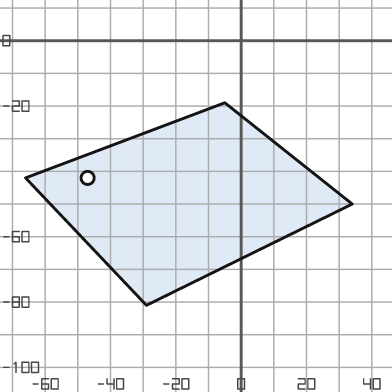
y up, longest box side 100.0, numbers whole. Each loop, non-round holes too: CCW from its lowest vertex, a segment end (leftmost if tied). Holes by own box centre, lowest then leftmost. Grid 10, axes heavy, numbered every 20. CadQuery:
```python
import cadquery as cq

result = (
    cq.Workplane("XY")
    .moveTo(-29.0, -81.0)
    .lineTo(34.0, -50.0)
    .lineTo(-5.0, -19.0)
    .lineTo(-66.0, -42.0)
    .close()
    .moveTo(-47.0, -42.0)
    .circle(2.0)
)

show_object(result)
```